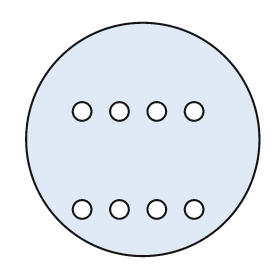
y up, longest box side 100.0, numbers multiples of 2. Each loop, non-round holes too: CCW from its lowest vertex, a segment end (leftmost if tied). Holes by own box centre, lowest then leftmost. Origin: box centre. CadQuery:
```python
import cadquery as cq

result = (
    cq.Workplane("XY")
    .moveTo(0.0, 0.0)
    .circle(50.0)
    .moveTo(-26.0, -30.0)
    .circle(4.0)
    .moveTo(-10.0, -30.0)
    .circle(4.0)
    .moveTo(6.0, -30.0)
    .circle(4.0)
    .moveTo(22.0, -30.0)
    .circle(4.0)
    .moveTo(-26.0, 12.0)
    .circle(4.0)
    .moveTo(-10.0, 12.0)
    .circle(4.0)
    .moveTo(6.0, 12.0)
    .circle(4.0)
    .moveTo(22.0, 12.0)
    .circle(4.0)
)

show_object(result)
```